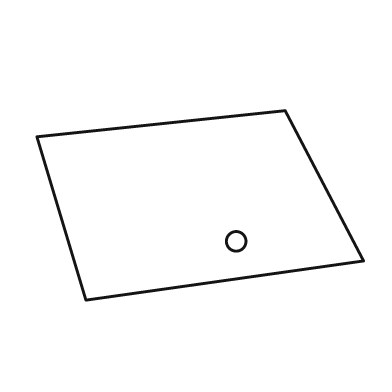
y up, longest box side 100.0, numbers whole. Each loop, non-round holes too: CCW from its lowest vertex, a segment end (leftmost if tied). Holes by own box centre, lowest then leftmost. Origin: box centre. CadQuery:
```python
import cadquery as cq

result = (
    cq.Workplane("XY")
    .moveTo(-35.0, -29.0)
    .lineTo(50.0, -17.0)
    .lineTo(26.0, 29.0)
    .lineTo(-50.0, 21.0)
    .close()
    .moveTo(11.0, -11.0)
    .circle(3.0)
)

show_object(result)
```